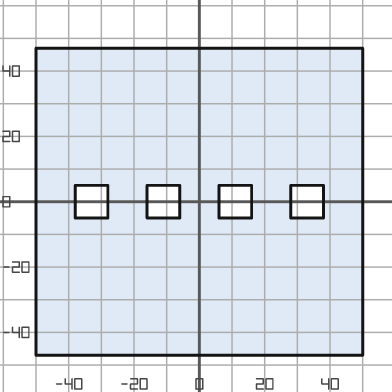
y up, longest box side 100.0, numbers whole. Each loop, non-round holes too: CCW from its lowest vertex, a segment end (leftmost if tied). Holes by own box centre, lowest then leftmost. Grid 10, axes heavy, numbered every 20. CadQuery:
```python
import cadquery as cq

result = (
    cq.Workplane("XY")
    .moveTo(-50.0, -47.0)
    .lineTo(50.0, -47.0)
    .lineTo(50.0, 47.0)
    .lineTo(-50.0, 47.0)
    .close()
    .moveTo(-38.0, -5.0)
    .lineTo(-28.0, -5.0)
    .lineTo(-28.0, 5.0)
    .lineTo(-38.0, 5.0)
    .close()
    .moveTo(-16.0, -5.0)
    .lineTo(-6.0, -5.0)
    .lineTo(-6.0, 5.0)
    .lineTo(-16.0, 5.0)
    .close()
    .moveTo(6.0, -5.0)
    .lineTo(16.0, -5.0)
    .lineTo(16.0, 5.0)
    .lineTo(6.0, 5.0)
    .close()
    .moveTo(28.0, -5.0)
    .lineTo(38.0, -5.0)
    .lineTo(38.0, 5.0)
    .lineTo(28.0, 5.0)
    .close()
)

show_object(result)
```